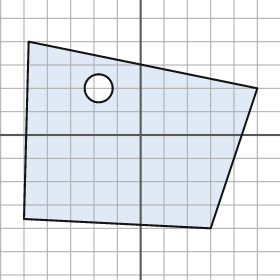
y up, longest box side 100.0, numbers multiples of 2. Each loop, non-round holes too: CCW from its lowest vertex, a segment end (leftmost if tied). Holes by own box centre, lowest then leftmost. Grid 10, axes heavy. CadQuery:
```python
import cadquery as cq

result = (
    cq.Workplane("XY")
    .moveTo(30.0, -40.0)
    .lineTo(50.0, 20.0)
    .lineTo(-48.0, 40.0)
    .lineTo(-50.0, -36.0)
    .close()
    .moveTo(-18.0, 20.0)
    .circle(6.0)
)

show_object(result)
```